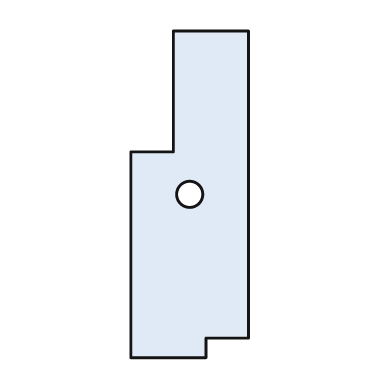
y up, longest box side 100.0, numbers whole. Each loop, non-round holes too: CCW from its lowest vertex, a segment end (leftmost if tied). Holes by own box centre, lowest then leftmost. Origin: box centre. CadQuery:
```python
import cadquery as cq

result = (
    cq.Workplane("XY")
    .moveTo(-18.0, -50.0)
    .lineTo(5.0, -50.0)
    .lineTo(5.0, -44.0)
    .lineTo(18.0, -44.0)
    .lineTo(18.0, 50.0)
    .lineTo(-5.0, 50.0)
    .lineTo(-5.0, 13.0)
    .lineTo(-18.0, 13.0)
    .close()
    .moveTo(0.0, 0.0)
    .circle(4.0)
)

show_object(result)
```